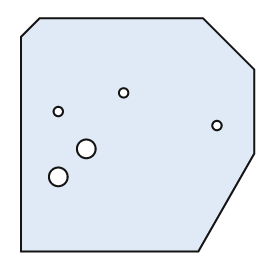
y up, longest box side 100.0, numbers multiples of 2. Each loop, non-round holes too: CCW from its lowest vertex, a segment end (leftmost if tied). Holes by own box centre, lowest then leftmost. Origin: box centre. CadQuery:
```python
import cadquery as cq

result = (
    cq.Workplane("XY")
    .moveTo(-50.0, -50.0)
    .lineTo(26.0, -50.0)
    .lineTo(50.0, -8.0)
    .lineTo(50.0, 28.0)
    .lineTo(28.0, 50.0)
    .lineTo(-42.0, 50.0)
    .lineTo(-50.0, 42.0)
    .close()
    .moveTo(-34.0, -18.0)
    .circle(4.0)
    .moveTo(-22.0, -6.0)
    .circle(4.0)
    .moveTo(34.0, 4.0)
    .circle(2.0)
    .moveTo(-34.0, 10.0)
    .circle(2.0)
    .moveTo(-6.0, 18.0)
    .circle(2.0)
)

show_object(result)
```